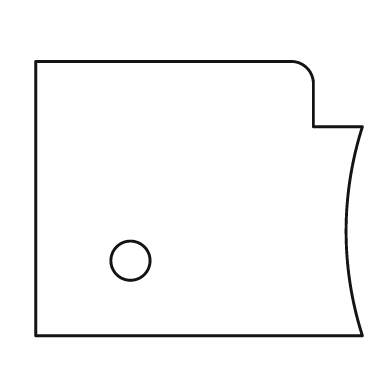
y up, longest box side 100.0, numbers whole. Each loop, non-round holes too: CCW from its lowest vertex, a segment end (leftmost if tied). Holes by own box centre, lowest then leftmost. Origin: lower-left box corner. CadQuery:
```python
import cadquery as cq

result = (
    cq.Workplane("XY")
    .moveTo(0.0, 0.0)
    .lineTo(100.0, 0.0)
    .threePointArc((95.0, 32.0), (100.0, 64.0))
    .lineTo(85.0, 64.0)
    .lineTo(85.0, 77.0)
    .threePointArc((83.0, 82.0), (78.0, 84.0))
    .lineTo(0.0, 84.0)
    .close()
    .moveTo(29.0, 23.0)
    .circle(6.0)
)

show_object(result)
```